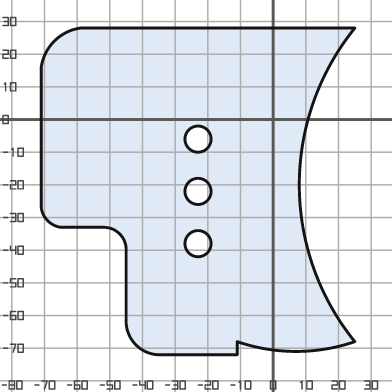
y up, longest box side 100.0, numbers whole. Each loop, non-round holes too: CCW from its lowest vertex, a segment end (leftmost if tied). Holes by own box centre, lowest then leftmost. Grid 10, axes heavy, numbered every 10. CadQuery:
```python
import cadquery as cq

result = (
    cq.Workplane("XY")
    .moveTo(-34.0, -72.0)
    .lineTo(-11.0, -72.0)
    .lineTo(-11.0, -68.0)
    .threePointArc((7.0, -71.0), (25.0, -68.0))
    .threePointArc((8.0, -20.0), (25.0, 28.0))
    .lineTo(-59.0, 28.0)
    .threePointArc((-67.0, 24.0), (-71.0, 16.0))
    .lineTo(-71.0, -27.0)
    .threePointArc((-69.0, -31.0), (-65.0, -33.0))
    .lineTo(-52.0, -33.0)
    .threePointArc((-47.0, -35.0), (-45.0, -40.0))
    .lineTo(-45.0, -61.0)
    .threePointArc((-42.0, -69.0), (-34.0, -72.0))
    .close()
    .moveTo(-23.0, -38.0)
    .circle(4.0)
    .moveTo(-23.0, -22.0)
    .circle(4.0)
    .moveTo(-23.0, -6.0)
    .circle(4.0)
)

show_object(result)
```